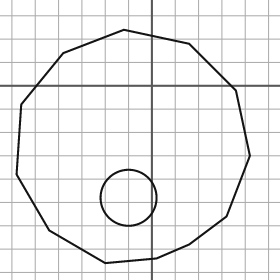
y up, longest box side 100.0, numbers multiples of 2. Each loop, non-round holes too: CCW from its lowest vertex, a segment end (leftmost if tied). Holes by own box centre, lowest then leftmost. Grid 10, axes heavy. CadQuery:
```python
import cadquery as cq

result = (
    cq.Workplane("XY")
    .moveTo(-20.0, -76.0)
    .lineTo(2.0, -74.0)
    .lineTo(16.0, -68.0)
    .lineTo(32.0, -56.0)
    .lineTo(42.0, -30.0)
    .lineTo(36.0, -2.0)
    .lineTo(16.0, 18.0)
    .lineTo(-12.0, 24.0)
    .lineTo(-38.0, 14.0)
    .lineTo(-56.0, -8.0)
    .lineTo(-58.0, -38.0)
    .lineTo(-44.0, -62.0)
    .close()
    .moveTo(-10.0, -48.0)
    .circle(12.0)
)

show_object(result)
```